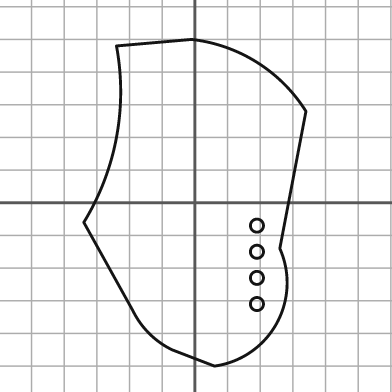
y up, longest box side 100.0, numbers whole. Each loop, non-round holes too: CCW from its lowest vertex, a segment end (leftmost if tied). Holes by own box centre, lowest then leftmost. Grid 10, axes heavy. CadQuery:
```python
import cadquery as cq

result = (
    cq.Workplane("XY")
    .moveTo(6.0, -50.0)
    .threePointArc((25.0, -37.0), (26.0, -14.0))
    .lineTo(34.0, 28.0)
    .threePointArc((19.0, 43.0), (-1.0, 50.0))
    .lineTo(-24.0, 48.0)
    .threePointArc((-24.0, 20.0), (-34.0, -6.0))
    .lineTo(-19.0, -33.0)
    .threePointArc((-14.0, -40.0), (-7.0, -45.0))
    .close()
    .moveTo(19.0, -31.0)
    .circle(2.0)
    .moveTo(19.0, -23.0)
    .circle(2.0)
    .moveTo(19.0, -15.0)
    .circle(2.0)
    .moveTo(19.0, -7.0)
    .circle(2.0)
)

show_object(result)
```